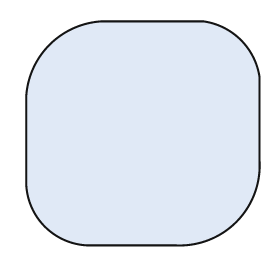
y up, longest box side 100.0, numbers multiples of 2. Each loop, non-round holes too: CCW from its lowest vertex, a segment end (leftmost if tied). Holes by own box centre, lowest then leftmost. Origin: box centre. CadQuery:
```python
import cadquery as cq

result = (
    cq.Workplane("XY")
    .moveTo(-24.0, -48.0)
    .lineTo(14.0, -48.0)
    .threePointArc((40.0, -38.0), (50.0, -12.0))
    .lineTo(50.0, 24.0)
    .threePointArc((42.0, 40.0), (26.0, 48.0))
    .lineTo(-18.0, 48.0)
    .threePointArc((-40.0, 38.0), (-50.0, 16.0))
    .lineTo(-50.0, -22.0)
    .threePointArc((-42.0, -40.0), (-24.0, -48.0))
    .close()
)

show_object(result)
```